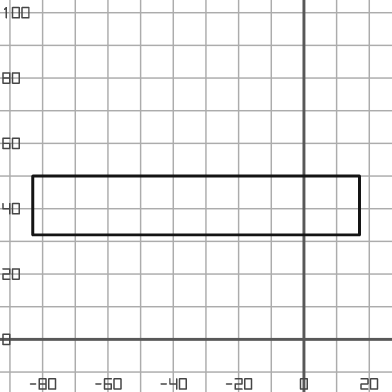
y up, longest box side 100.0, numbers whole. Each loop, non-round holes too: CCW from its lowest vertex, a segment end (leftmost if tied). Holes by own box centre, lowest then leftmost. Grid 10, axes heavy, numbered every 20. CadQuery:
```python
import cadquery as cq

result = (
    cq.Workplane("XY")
    .moveTo(-83.0, 32.0)
    .lineTo(17.0, 32.0)
    .lineTo(17.0, 50.0)
    .lineTo(-83.0, 50.0)
    .close()
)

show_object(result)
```